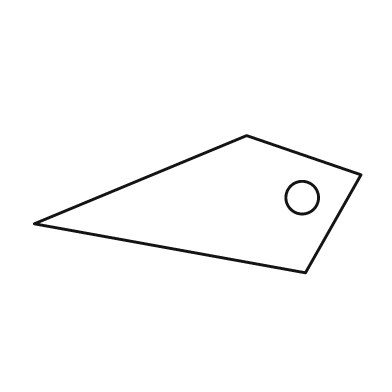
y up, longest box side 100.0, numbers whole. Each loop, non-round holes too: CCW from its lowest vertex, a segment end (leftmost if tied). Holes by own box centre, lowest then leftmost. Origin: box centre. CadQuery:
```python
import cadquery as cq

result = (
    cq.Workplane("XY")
    .moveTo(33.0, -21.0)
    .lineTo(50.0, 9.0)
    .lineTo(15.0, 21.0)
    .lineTo(-50.0, -6.0)
    .close()
    .moveTo(32.0, 2.0)
    .circle(5.0)
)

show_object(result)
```